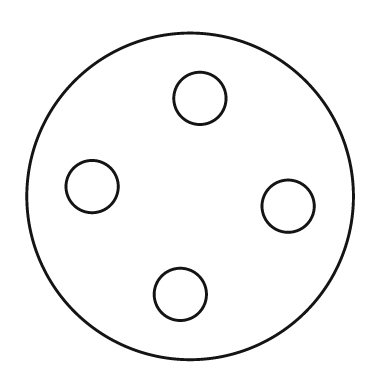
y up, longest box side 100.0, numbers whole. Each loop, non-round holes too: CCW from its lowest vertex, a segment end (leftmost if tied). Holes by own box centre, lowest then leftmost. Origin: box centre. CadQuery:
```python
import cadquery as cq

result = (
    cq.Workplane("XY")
    .moveTo(0.0, 0.0)
    .circle(50.0)
    .moveTo(-3.0, -30.0)
    .circle(8.0)
    .moveTo(30.0, -3.0)
    .circle(8.0)
    .moveTo(-30.0, 3.0)
    .circle(8.0)
    .moveTo(3.0, 30.0)
    .circle(8.0)
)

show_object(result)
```